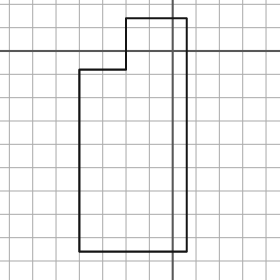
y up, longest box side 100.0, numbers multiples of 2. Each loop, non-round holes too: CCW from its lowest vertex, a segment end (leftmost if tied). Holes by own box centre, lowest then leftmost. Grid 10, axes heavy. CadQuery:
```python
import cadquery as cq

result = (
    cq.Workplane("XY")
    .moveTo(-40.0, -86.0)
    .lineTo(6.0, -86.0)
    .lineTo(6.0, 14.0)
    .lineTo(-20.0, 14.0)
    .lineTo(-20.0, -8.0)
    .lineTo(-40.0, -8.0)
    .close()
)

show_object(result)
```